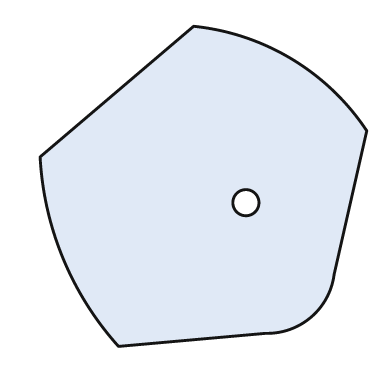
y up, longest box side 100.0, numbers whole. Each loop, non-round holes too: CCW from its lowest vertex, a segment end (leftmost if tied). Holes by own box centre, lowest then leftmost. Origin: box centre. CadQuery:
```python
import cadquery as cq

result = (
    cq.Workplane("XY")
    .moveTo(-26.0, -49.0)
    .lineTo(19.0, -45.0)
    .threePointArc((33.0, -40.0), (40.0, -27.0))
    .lineTo(50.0, 17.0)
    .threePointArc((27.0, 39.0), (-3.0, 49.0))
    .lineTo(-50.0, 9.0)
    .threePointArc((-43.0, -22.0), (-26.0, -49.0))
    .close()
    .moveTo(13.0, -5.0)
    .circle(4.0)
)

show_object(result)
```